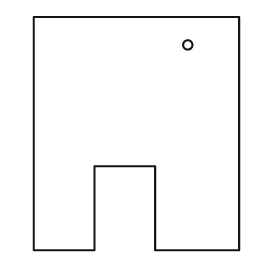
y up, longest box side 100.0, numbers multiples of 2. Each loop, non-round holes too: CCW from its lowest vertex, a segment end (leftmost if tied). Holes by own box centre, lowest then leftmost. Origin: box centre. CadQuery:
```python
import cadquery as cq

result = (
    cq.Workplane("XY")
    .moveTo(-44.0, -50.0)
    .lineTo(-18.0, -50.0)
    .lineTo(-18.0, -14.0)
    .lineTo(8.0, -14.0)
    .lineTo(8.0, -50.0)
    .lineTo(44.0, -50.0)
    .lineTo(44.0, 50.0)
    .lineTo(-44.0, 50.0)
    .close()
    .moveTo(22.0, 38.0)
    .circle(2.0)
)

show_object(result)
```